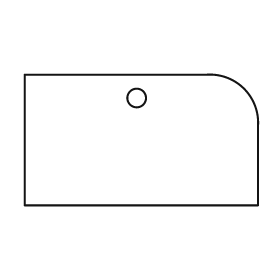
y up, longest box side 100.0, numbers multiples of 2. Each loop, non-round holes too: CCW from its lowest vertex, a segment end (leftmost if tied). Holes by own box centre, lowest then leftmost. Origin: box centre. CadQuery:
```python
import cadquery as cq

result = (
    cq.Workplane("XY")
    .moveTo(-50.0, -28.0)
    .lineTo(50.0, -28.0)
    .lineTo(50.0, 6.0)
    .threePointArc((44.0, 22.0), (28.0, 28.0))
    .lineTo(-50.0, 28.0)
    .close()
    .moveTo(-2.0, 18.0)
    .circle(4.0)
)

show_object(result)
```